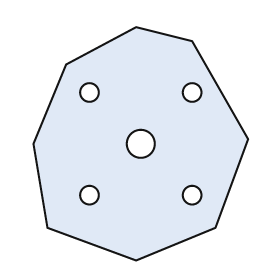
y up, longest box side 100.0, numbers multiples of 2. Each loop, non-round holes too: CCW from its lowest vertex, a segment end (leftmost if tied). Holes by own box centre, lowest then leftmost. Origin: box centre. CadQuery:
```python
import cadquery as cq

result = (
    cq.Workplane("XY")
    .moveTo(-2.0, -50.0)
    .lineTo(32.0, -36.0)
    .lineTo(46.0, 2.0)
    .lineTo(22.0, 44.0)
    .lineTo(-2.0, 50.0)
    .lineTo(-32.0, 34.0)
    .lineTo(-46.0, 0.0)
    .lineTo(-40.0, -36.0)
    .close()
    .moveTo(-22.0, -22.0)
    .circle(4.0)
    .moveTo(22.0, -22.0)
    .circle(4.0)
    .moveTo(0.0, 0.0)
    .circle(6.0)
    .moveTo(-22.0, 22.0)
    .circle(4.0)
    .moveTo(22.0, 22.0)
    .circle(4.0)
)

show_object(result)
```